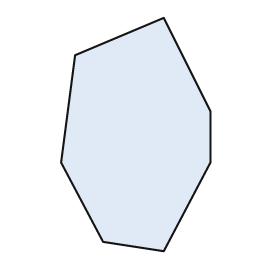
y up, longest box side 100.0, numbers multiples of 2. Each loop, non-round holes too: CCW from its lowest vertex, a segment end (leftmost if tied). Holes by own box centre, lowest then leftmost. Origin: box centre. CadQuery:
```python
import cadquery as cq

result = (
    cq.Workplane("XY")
    .moveTo(12.0, -50.0)
    .lineTo(32.0, -12.0)
    .lineTo(32.0, 10.0)
    .lineTo(12.0, 50.0)
    .lineTo(-26.0, 34.0)
    .lineTo(-32.0, -12.0)
    .lineTo(-14.0, -46.0)
    .close()
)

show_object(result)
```